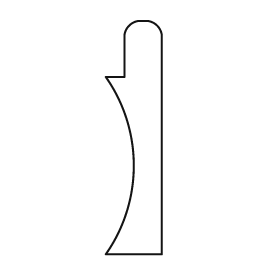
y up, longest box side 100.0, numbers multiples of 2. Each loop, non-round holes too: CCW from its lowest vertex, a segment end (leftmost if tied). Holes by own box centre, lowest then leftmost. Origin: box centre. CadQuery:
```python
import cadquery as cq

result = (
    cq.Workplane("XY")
    .moveTo(-12.0, -50.0)
    .lineTo(12.0, -50.0)
    .lineTo(12.0, 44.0)
    .threePointArc((10.0, 48.0), (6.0, 50.0))
    .lineTo(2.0, 50.0)
    .threePointArc((-2.0, 48.0), (-4.0, 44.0))
    .lineTo(-4.0, 26.0)
    .lineTo(-12.0, 26.0)
    .threePointArc((0.0, -12.0), (-12.0, -50.0))
    .close()
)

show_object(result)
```